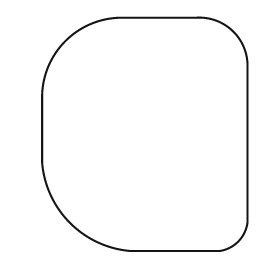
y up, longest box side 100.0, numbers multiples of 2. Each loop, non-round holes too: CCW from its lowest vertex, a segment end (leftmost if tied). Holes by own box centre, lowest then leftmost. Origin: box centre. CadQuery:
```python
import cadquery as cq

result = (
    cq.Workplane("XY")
    .moveTo(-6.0, -50.0)
    .lineTo(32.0, -50.0)
    .threePointArc((40.0, -46.0), (44.0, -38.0))
    .lineTo(44.0, 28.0)
    .threePointArc((38.0, 44.0), (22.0, 50.0))
    .lineTo(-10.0, 50.0)
    .threePointArc((-34.0, 40.0), (-44.0, 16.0))
    .lineTo(-44.0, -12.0)
    .threePointArc((-32.0, -38.0), (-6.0, -50.0))
    .close()
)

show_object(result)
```